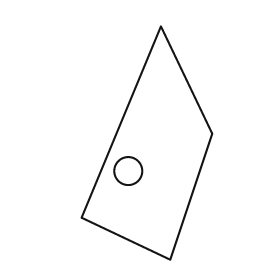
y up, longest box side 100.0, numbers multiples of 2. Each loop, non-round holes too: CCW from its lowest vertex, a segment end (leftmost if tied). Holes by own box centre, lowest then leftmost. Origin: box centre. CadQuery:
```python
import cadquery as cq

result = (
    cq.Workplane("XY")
    .moveTo(10.0, -50.0)
    .lineTo(28.0, 4.0)
    .lineTo(6.0, 50.0)
    .lineTo(-28.0, -32.0)
    .close()
    .moveTo(-8.0, -12.0)
    .circle(6.0)
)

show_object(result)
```